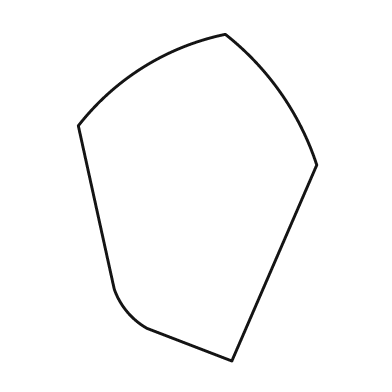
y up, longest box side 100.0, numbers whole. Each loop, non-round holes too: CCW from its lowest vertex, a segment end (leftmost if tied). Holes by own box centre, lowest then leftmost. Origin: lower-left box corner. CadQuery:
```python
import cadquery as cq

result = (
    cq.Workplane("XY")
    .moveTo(47.0, 0.0)
    .lineTo(73.0, 60.0)
    .threePointArc((62.0, 82.0), (45.0, 100.0))
    .threePointArc((20.0, 90.0), (0.0, 72.0))
    .lineTo(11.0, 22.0)
    .threePointArc((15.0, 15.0), (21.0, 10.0))
    .close()
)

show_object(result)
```